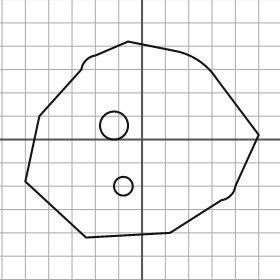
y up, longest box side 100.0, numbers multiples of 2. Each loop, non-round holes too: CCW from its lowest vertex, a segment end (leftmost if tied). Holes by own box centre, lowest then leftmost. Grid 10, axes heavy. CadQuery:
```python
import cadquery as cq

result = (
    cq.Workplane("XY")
    .moveTo(-24.0, -42.0)
    .lineTo(12.0, -40.0)
    .lineTo(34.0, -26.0)
    .threePointArc((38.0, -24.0), (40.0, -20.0))
    .lineTo(50.0, 2.0)
    .lineTo(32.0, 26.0)
    .threePointArc((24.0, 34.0), (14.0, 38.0))
    .lineTo(-6.0, 42.0)
    .lineTo(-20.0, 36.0)
    .threePointArc((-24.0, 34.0), (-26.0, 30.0))
    .lineTo(-44.0, 10.0)
    .lineTo(-50.0, -18.0)
    .close()
    .moveTo(-8.0, -20.0)
    .circle(4.0)
    .moveTo(-12.0, 6.0)
    .circle(6.0)
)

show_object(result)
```